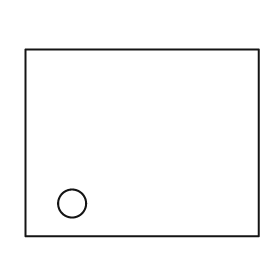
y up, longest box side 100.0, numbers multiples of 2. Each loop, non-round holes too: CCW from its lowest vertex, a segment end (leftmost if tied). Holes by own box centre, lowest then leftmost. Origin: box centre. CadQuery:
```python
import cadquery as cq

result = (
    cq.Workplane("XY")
    .moveTo(-50.0, -40.0)
    .lineTo(50.0, -40.0)
    .lineTo(50.0, 40.0)
    .lineTo(-50.0, 40.0)
    .close()
    .moveTo(-30.0, -26.0)
    .circle(6.0)
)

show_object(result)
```